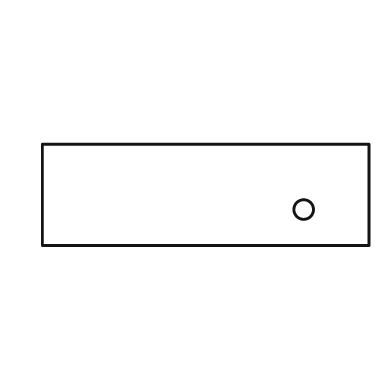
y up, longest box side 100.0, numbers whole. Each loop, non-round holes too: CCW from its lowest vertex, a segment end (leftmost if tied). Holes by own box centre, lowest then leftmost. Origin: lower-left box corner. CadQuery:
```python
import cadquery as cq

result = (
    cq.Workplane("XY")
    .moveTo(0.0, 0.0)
    .lineTo(100.0, 0.0)
    .lineTo(100.0, 31.0)
    .lineTo(0.0, 31.0)
    .close()
    .moveTo(80.0, 11.0)
    .circle(3.0)
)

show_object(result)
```